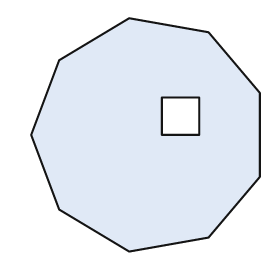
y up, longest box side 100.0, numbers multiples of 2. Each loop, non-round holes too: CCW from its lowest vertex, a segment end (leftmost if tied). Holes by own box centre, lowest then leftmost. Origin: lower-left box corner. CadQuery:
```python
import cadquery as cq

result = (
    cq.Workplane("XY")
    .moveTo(42.0, 0.0)
    .lineTo(76.0, 6.0)
    .lineTo(98.0, 32.0)
    .lineTo(98.0, 68.0)
    .lineTo(76.0, 94.0)
    .lineTo(42.0, 100.0)
    .lineTo(12.0, 82.0)
    .lineTo(0.0, 50.0)
    .lineTo(12.0, 18.0)
    .close()
    .moveTo(56.0, 50.0)
    .lineTo(72.0, 50.0)
    .lineTo(72.0, 66.0)
    .lineTo(56.0, 66.0)
    .close()
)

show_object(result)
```